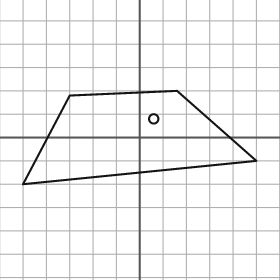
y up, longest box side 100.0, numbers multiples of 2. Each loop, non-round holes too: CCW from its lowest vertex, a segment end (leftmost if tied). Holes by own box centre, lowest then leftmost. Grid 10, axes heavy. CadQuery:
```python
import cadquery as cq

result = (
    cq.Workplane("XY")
    .moveTo(-50.0, -20.0)
    .lineTo(50.0, -10.0)
    .lineTo(16.0, 20.0)
    .lineTo(-30.0, 18.0)
    .close()
    .moveTo(6.0, 8.0)
    .circle(2.0)
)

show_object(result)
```